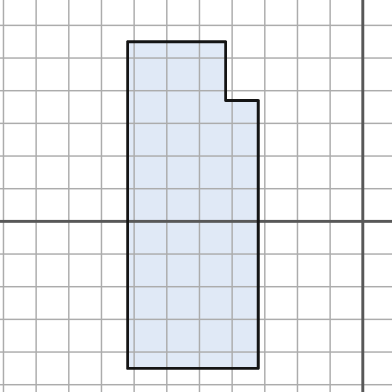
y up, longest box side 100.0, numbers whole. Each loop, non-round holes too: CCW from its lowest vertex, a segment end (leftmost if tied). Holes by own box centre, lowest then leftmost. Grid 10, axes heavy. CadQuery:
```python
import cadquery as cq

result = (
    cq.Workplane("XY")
    .moveTo(-72.0, -45.0)
    .lineTo(-32.0, -45.0)
    .lineTo(-32.0, 37.0)
    .lineTo(-42.0, 37.0)
    .lineTo(-42.0, 55.0)
    .lineTo(-72.0, 55.0)
    .close()
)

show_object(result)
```